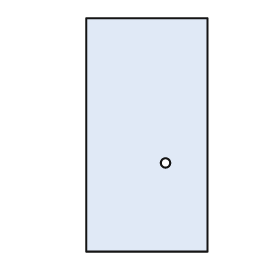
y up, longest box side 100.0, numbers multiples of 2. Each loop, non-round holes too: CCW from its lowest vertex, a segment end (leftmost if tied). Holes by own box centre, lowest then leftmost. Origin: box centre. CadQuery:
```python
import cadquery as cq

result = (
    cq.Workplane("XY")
    .moveTo(-26.0, -50.0)
    .lineTo(26.0, -50.0)
    .lineTo(26.0, 50.0)
    .lineTo(-26.0, 50.0)
    .close()
    .moveTo(8.0, -12.0)
    .circle(2.0)
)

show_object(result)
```